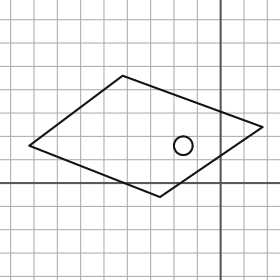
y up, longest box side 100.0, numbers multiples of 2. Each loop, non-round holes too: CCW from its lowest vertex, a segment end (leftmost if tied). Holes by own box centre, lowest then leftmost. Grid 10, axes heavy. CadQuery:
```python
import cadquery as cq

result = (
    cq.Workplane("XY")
    .moveTo(-26.0, -6.0)
    .lineTo(18.0, 24.0)
    .lineTo(-42.0, 46.0)
    .lineTo(-82.0, 16.0)
    .close()
    .moveTo(-16.0, 16.0)
    .circle(4.0)
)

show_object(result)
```